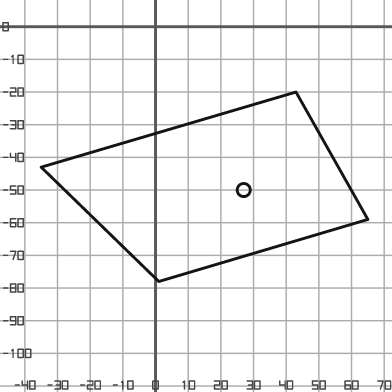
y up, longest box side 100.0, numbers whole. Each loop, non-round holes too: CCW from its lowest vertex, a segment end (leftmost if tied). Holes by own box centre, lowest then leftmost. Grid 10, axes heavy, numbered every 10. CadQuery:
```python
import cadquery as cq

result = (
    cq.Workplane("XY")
    .moveTo(1.0, -78.0)
    .lineTo(65.0, -59.0)
    .lineTo(43.0, -20.0)
    .lineTo(-35.0, -43.0)
    .close()
    .moveTo(27.0, -50.0)
    .circle(2.0)
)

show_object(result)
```